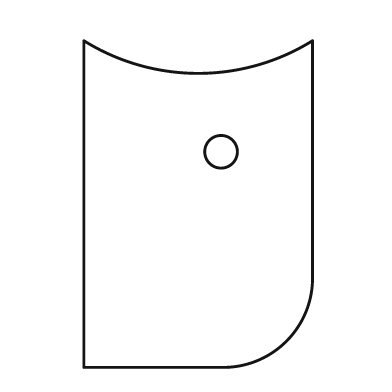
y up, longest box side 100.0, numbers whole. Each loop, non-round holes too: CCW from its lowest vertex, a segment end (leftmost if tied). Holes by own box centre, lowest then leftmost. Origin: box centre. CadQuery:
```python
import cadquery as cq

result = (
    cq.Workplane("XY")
    .moveTo(-35.0, -50.0)
    .lineTo(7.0, -50.0)
    .threePointArc((27.0, -42.0), (35.0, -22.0))
    .lineTo(35.0, 50.0)
    .threePointArc((0.0, 40.0), (-35.0, 50.0))
    .close()
    .moveTo(7.0, 16.0)
    .circle(5.0)
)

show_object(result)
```